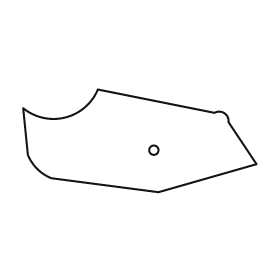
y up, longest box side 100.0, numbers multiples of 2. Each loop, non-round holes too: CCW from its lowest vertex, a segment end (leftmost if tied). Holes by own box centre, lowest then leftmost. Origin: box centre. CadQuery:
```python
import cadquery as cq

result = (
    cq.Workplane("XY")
    .moveTo(8.0, -22.0)
    .lineTo(50.0, -10.0)
    .lineTo(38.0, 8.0)
    .threePointArc((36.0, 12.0), (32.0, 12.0))
    .lineTo(-18.0, 22.0)
    .threePointArc((-32.0, 10.0), (-50.0, 14.0))
    .lineTo(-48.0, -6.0)
    .threePointArc((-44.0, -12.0), (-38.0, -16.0))
    .close()
    .moveTo(6.0, -4.0)
    .circle(2.0)
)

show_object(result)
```